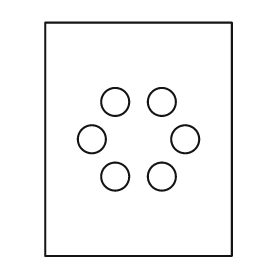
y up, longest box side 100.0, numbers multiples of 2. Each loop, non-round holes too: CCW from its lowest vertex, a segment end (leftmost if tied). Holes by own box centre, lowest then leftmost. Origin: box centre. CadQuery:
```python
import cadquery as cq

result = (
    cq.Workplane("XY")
    .moveTo(-40.0, -50.0)
    .lineTo(40.0, -50.0)
    .lineTo(40.0, 50.0)
    .lineTo(-40.0, 50.0)
    .close()
    .moveTo(-10.0, -16.0)
    .circle(6.0)
    .moveTo(10.0, -16.0)
    .circle(6.0)
    .moveTo(-20.0, 0.0)
    .circle(6.0)
    .moveTo(20.0, 0.0)
    .circle(6.0)
    .moveTo(-10.0, 16.0)
    .circle(6.0)
    .moveTo(10.0, 16.0)
    .circle(6.0)
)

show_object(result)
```